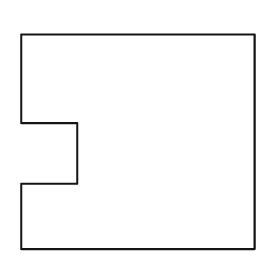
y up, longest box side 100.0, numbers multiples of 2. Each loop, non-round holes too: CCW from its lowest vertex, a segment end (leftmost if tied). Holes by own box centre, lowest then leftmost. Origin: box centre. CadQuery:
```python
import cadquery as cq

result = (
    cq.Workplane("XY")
    .moveTo(-50.0, -46.0)
    .lineTo(50.0, -46.0)
    .lineTo(50.0, 46.0)
    .lineTo(-50.0, 46.0)
    .lineTo(-50.0, 8.0)
    .lineTo(-26.0, 8.0)
    .lineTo(-26.0, -18.0)
    .lineTo(-50.0, -18.0)
    .close()
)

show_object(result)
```